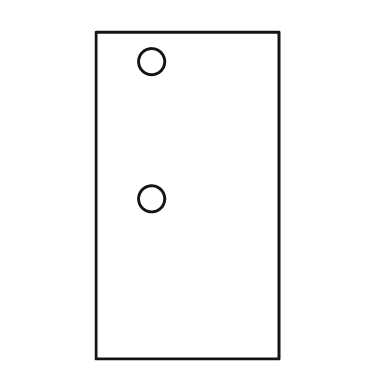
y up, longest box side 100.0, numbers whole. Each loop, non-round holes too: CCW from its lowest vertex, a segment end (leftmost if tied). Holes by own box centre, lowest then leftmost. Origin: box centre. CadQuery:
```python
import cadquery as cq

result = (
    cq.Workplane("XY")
    .moveTo(-28.0, -50.0)
    .lineTo(28.0, -50.0)
    .lineTo(28.0, 50.0)
    .lineTo(-28.0, 50.0)
    .close()
    .moveTo(-11.0, -1.0)
    .circle(4.0)
    .moveTo(-11.0, 41.0)
    .circle(4.0)
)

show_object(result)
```